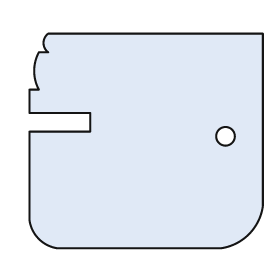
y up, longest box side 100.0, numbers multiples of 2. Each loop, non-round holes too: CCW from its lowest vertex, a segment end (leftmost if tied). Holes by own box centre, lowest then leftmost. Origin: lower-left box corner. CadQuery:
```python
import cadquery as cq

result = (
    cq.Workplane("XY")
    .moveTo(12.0, 0.0)
    .lineTo(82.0, 0.0)
    .threePointArc((94.0, 6.0), (100.0, 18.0))
    .lineTo(100.0, 92.0)
    .lineTo(8.0, 92.0)
    .threePointArc((6.0, 88.0), (8.0, 84.0))
    .lineTo(4.0, 84.0)
    .threePointArc((2.0, 76.0), (4.0, 68.0))
    .lineTo(0.0, 68.0)
    .lineTo(0.0, 58.0)
    .lineTo(26.0, 58.0)
    .lineTo(26.0, 50.0)
    .lineTo(0.0, 50.0)
    .lineTo(0.0, 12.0)
    .threePointArc((4.0, 4.0), (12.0, 0.0))
    .close()
    .moveTo(84.0, 48.0)
    .circle(4.0)
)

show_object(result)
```